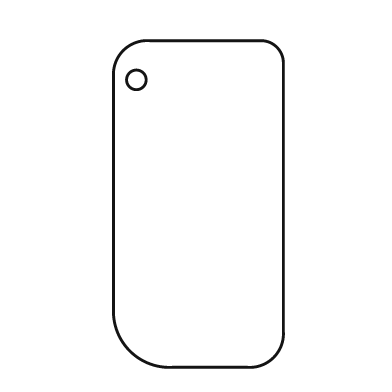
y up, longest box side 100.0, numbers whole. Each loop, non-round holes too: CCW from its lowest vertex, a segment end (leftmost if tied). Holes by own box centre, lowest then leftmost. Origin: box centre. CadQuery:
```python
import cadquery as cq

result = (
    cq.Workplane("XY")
    .moveTo(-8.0, -50.0)
    .lineTo(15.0, -50.0)
    .threePointArc((23.0, -47.0), (26.0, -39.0))
    .lineTo(26.0, 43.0)
    .threePointArc((24.0, 48.0), (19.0, 50.0))
    .lineTo(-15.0, 50.0)
    .threePointArc((-23.0, 47.0), (-26.0, 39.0))
    .lineTo(-26.0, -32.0)
    .threePointArc((-21.0, -45.0), (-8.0, -50.0))
    .close()
    .moveTo(-19.0, 38.0)
    .circle(3.0)
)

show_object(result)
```